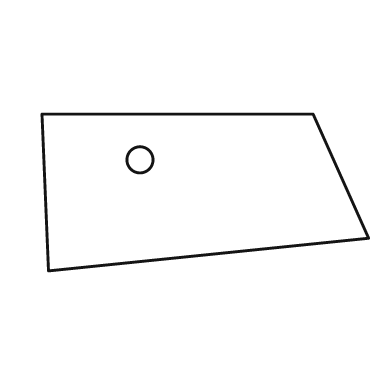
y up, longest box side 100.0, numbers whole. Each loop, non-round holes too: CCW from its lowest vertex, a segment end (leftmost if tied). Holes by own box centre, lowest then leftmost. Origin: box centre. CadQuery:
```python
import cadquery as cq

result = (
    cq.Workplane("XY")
    .moveTo(-48.0, -24.0)
    .lineTo(50.0, -14.0)
    .lineTo(33.0, 24.0)
    .lineTo(-50.0, 24.0)
    .close()
    .moveTo(-20.0, 10.0)
    .circle(4.0)
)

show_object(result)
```